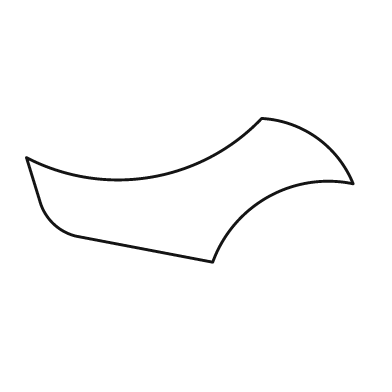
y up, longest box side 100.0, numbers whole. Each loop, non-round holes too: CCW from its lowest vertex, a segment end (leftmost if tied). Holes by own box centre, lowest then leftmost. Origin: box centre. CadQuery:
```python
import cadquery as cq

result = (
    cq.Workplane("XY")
    .moveTo(7.0, -22.0)
    .threePointArc((24.0, -2.0), (50.0, 2.0))
    .threePointArc((39.0, 16.0), (22.0, 22.0))
    .threePointArc((-12.0, 4.0), (-50.0, 10.0))
    .lineTo(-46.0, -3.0)
    .threePointArc((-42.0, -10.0), (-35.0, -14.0))
    .close()
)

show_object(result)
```